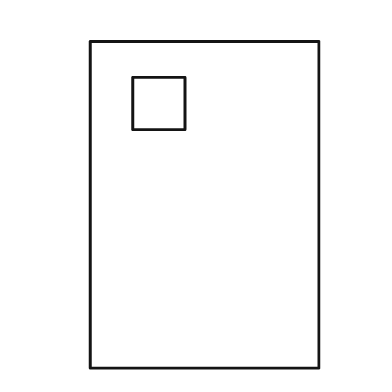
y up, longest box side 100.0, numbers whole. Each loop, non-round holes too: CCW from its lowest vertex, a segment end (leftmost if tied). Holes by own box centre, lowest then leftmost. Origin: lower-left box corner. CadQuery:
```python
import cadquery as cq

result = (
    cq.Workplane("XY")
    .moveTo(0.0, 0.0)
    .lineTo(70.0, 0.0)
    .lineTo(70.0, 100.0)
    .lineTo(0.0, 100.0)
    .close()
    .moveTo(13.0, 73.0)
    .lineTo(29.0, 73.0)
    .lineTo(29.0, 89.0)
    .lineTo(13.0, 89.0)
    .close()
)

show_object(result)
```